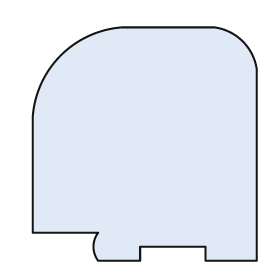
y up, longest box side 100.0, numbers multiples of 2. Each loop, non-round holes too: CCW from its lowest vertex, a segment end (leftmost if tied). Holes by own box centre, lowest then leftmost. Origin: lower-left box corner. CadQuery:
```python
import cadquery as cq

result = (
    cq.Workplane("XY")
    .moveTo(28.0, 0.0)
    .lineTo(46.0, 0.0)
    .lineTo(46.0, 6.0)
    .lineTo(74.0, 6.0)
    .lineTo(74.0, 0.0)
    .lineTo(96.0, 0.0)
    .lineTo(96.0, 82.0)
    .threePointArc((90.0, 94.0), (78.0, 100.0))
    .lineTo(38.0, 100.0)
    .threePointArc((12.0, 88.0), (0.0, 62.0))
    .lineTo(0.0, 12.0)
    .lineTo(28.0, 12.0)
    .threePointArc((26.0, 6.0), (28.0, 0.0))
    .close()
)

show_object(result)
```